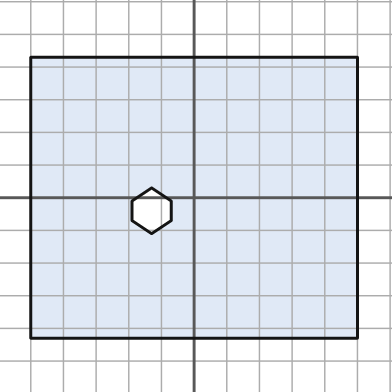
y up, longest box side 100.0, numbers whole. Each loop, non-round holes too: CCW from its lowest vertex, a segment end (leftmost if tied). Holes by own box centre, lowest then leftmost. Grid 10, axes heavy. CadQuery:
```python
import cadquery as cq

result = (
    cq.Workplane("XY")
    .moveTo(-50.0, -43.0)
    .lineTo(50.0, -43.0)
    .lineTo(50.0, 43.0)
    .lineTo(-50.0, 43.0)
    .close()
    .moveTo(-13.0, -11.0)
    .lineTo(-7.0, -7.0)
    .lineTo(-7.0, -1.0)
    .lineTo(-13.0, 3.0)
    .lineTo(-19.0, -1.0)
    .lineTo(-19.0, -7.0)
    .close()
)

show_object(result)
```